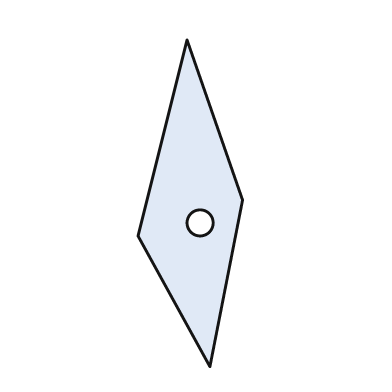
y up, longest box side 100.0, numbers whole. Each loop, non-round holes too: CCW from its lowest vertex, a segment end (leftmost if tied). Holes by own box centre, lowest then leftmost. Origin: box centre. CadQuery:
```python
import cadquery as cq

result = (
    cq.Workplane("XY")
    .moveTo(6.0, -50.0)
    .lineTo(16.0, 1.0)
    .lineTo(-1.0, 50.0)
    .lineTo(-16.0, -10.0)
    .close()
    .moveTo(3.0, -6.0)
    .circle(4.0)
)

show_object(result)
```